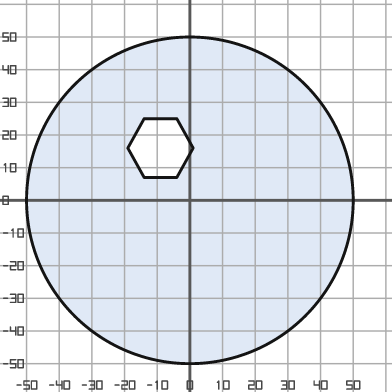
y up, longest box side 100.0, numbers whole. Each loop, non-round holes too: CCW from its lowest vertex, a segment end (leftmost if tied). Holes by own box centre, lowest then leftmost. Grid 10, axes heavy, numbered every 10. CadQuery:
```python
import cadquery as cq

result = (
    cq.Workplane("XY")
    .moveTo(0.0, 0.0)
    .circle(50.0)
    .moveTo(-14.0, 7.0)
    .lineTo(-4.0, 7.0)
    .lineTo(1.0, 16.0)
    .lineTo(-4.0, 25.0)
    .lineTo(-14.0, 25.0)
    .lineTo(-19.0, 16.0)
    .close()
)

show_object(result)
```